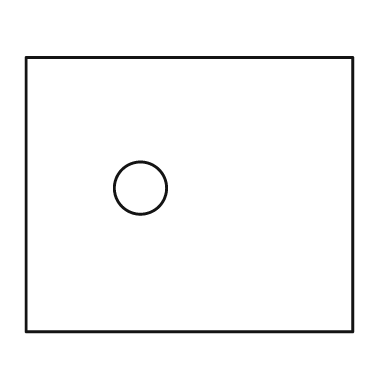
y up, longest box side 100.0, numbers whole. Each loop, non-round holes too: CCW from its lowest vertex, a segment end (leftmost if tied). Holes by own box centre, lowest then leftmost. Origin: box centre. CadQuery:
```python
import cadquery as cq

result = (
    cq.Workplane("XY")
    .moveTo(-50.0, -42.0)
    .lineTo(50.0, -42.0)
    .lineTo(50.0, 42.0)
    .lineTo(-50.0, 42.0)
    .close()
    .moveTo(-15.0, 2.0)
    .circle(8.0)
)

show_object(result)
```